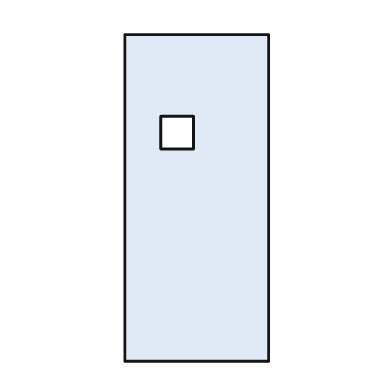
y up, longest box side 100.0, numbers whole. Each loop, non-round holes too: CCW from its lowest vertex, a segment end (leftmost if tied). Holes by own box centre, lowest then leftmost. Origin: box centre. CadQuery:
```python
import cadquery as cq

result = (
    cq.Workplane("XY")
    .moveTo(-22.0, -50.0)
    .lineTo(22.0, -50.0)
    .lineTo(22.0, 50.0)
    .lineTo(-22.0, 50.0)
    .close()
    .moveTo(-11.0, 15.0)
    .lineTo(-1.0, 15.0)
    .lineTo(-1.0, 25.0)
    .lineTo(-11.0, 25.0)
    .close()
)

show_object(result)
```